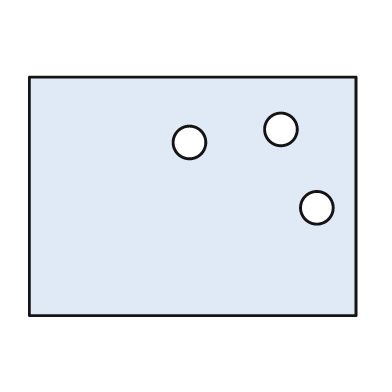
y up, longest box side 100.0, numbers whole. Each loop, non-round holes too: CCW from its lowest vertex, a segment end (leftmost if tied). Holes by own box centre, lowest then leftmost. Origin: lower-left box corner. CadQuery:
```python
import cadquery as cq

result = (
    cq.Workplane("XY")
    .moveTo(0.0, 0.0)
    .lineTo(100.0, 0.0)
    .lineTo(100.0, 73.0)
    .lineTo(0.0, 73.0)
    .close()
    .moveTo(88.0, 33.0)
    .circle(5.0)
    .moveTo(49.0, 53.0)
    .circle(5.0)
    .moveTo(77.0, 57.0)
    .circle(5.0)
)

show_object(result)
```